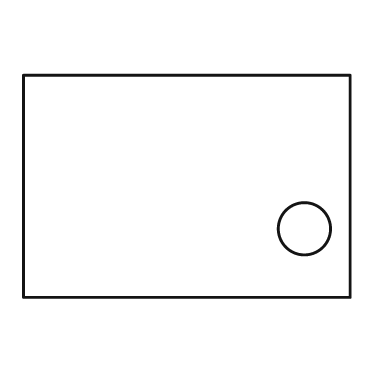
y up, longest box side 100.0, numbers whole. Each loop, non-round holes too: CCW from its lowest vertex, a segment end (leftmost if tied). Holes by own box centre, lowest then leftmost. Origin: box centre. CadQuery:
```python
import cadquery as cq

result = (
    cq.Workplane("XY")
    .moveTo(-50.0, -34.0)
    .lineTo(50.0, -34.0)
    .lineTo(50.0, 34.0)
    .lineTo(-50.0, 34.0)
    .close()
    .moveTo(36.0, -13.0)
    .circle(8.0)
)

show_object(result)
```